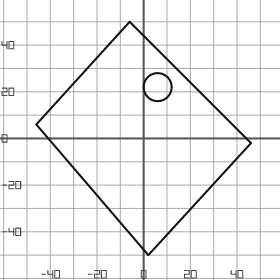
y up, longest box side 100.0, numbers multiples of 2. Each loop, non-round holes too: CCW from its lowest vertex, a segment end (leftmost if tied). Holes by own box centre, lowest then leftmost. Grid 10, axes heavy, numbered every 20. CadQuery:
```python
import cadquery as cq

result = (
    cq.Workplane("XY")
    .moveTo(2.0, -50.0)
    .lineTo(46.0, -2.0)
    .lineTo(-6.0, 50.0)
    .lineTo(-46.0, 6.0)
    .close()
    .moveTo(6.0, 22.0)
    .circle(6.0)
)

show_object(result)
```